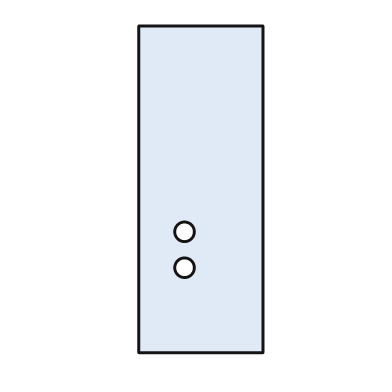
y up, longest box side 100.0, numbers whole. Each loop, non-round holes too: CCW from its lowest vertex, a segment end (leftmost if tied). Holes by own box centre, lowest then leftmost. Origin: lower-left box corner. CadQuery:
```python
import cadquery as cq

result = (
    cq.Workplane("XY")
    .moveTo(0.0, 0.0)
    .lineTo(38.0, 0.0)
    .lineTo(38.0, 100.0)
    .lineTo(0.0, 100.0)
    .close()
    .moveTo(14.0, 26.0)
    .circle(3.0)
    .moveTo(14.0, 37.0)
    .circle(3.0)
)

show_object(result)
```